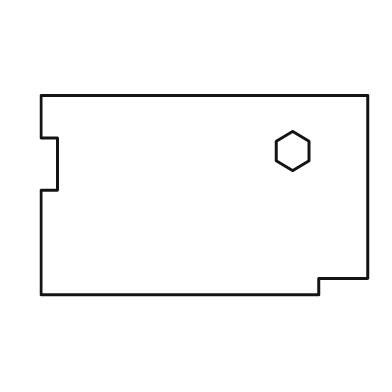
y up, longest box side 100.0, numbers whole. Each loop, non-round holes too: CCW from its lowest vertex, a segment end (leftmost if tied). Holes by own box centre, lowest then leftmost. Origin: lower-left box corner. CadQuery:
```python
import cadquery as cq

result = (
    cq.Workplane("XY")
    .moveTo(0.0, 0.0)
    .lineTo(85.0, 0.0)
    .lineTo(85.0, 5.0)
    .lineTo(100.0, 5.0)
    .lineTo(100.0, 61.0)
    .lineTo(0.0, 61.0)
    .lineTo(0.0, 48.0)
    .lineTo(5.0, 48.0)
    .lineTo(5.0, 32.0)
    .lineTo(0.0, 32.0)
    .close()
    .moveTo(77.0, 38.0)
    .lineTo(82.0, 41.0)
    .lineTo(82.0, 47.0)
    .lineTo(77.0, 50.0)
    .lineTo(72.0, 47.0)
    .lineTo(72.0, 41.0)
    .close()
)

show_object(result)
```